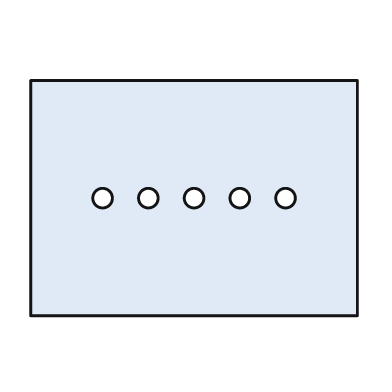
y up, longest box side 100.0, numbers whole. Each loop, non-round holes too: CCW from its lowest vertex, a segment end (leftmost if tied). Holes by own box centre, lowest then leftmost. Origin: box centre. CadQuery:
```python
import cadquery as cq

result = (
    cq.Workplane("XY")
    .moveTo(-50.0, -36.0)
    .lineTo(50.0, -36.0)
    .lineTo(50.0, 36.0)
    .lineTo(-50.0, 36.0)
    .close()
    .moveTo(-28.0, 0.0)
    .circle(3.0)
    .moveTo(-14.0, 0.0)
    .circle(3.0)
    .moveTo(0.0, 0.0)
    .circle(3.0)
    .moveTo(14.0, 0.0)
    .circle(3.0)
    .moveTo(28.0, 0.0)
    .circle(3.0)
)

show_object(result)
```